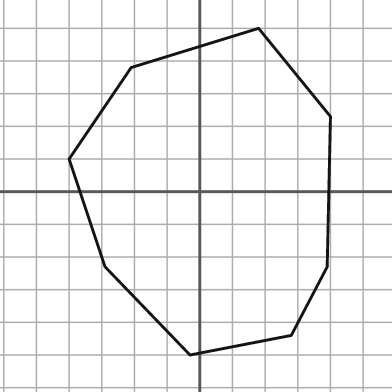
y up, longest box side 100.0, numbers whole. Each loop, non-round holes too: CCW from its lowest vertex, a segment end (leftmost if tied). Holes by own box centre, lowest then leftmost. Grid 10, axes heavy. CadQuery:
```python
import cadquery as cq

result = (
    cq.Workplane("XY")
    .moveTo(-3.0, -50.0)
    .lineTo(28.0, -44.0)
    .lineTo(39.0, -23.0)
    .lineTo(40.0, 23.0)
    .lineTo(18.0, 50.0)
    .lineTo(-21.0, 38.0)
    .lineTo(-40.0, 10.0)
    .lineTo(-29.0, -23.0)
    .close()
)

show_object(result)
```